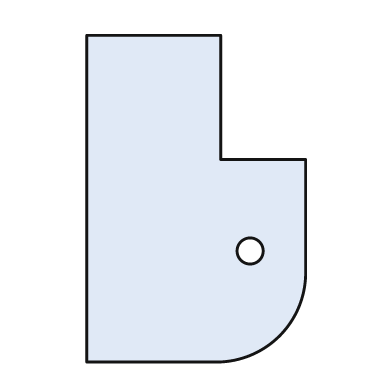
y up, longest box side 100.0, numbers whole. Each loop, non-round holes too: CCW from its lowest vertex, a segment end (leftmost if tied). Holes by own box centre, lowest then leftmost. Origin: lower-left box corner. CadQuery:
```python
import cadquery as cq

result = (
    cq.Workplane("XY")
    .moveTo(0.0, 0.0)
    .lineTo(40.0, 0.0)
    .threePointArc((59.0, 8.0), (67.0, 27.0))
    .lineTo(67.0, 62.0)
    .lineTo(41.0, 62.0)
    .lineTo(41.0, 100.0)
    .lineTo(0.0, 100.0)
    .close()
    .moveTo(50.0, 34.0)
    .circle(4.0)
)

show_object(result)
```